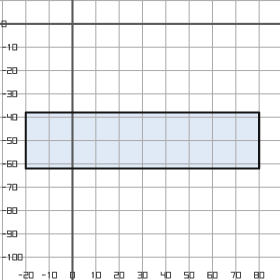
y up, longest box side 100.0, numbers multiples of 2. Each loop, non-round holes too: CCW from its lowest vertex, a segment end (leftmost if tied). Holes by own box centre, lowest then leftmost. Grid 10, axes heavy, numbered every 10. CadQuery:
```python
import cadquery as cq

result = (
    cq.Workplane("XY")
    .moveTo(-20.0, -62.0)
    .lineTo(80.0, -62.0)
    .lineTo(80.0, -38.0)
    .lineTo(-20.0, -38.0)
    .close()
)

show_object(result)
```